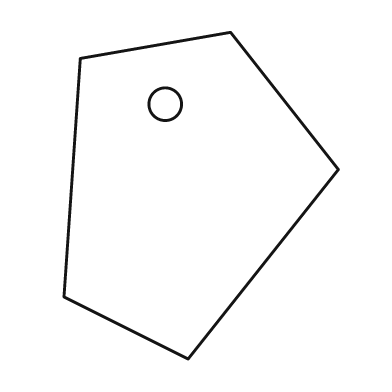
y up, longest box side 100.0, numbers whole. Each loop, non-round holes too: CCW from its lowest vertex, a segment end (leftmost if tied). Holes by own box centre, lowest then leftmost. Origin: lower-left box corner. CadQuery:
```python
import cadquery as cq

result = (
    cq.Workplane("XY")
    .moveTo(38.0, 0.0)
    .lineTo(84.0, 58.0)
    .lineTo(51.0, 100.0)
    .lineTo(5.0, 92.0)
    .lineTo(0.0, 19.0)
    .close()
    .moveTo(31.0, 78.0)
    .circle(5.0)
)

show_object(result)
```